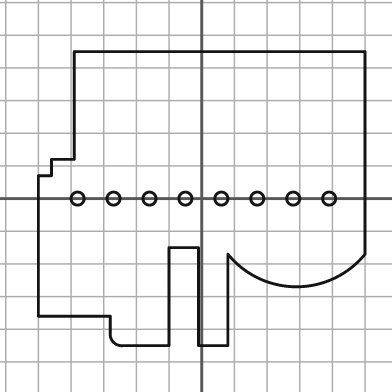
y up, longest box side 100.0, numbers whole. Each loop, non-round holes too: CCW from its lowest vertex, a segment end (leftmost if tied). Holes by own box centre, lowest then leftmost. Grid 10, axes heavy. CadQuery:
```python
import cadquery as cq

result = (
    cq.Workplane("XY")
    .moveTo(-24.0, -45.0)
    .lineTo(-10.0, -45.0)
    .lineTo(-10.0, -15.0)
    .lineTo(-1.0, -15.0)
    .lineTo(-1.0, -45.0)
    .lineTo(8.0, -45.0)
    .lineTo(8.0, -17.0)
    .threePointArc((29.0, -27.0), (50.0, -17.0))
    .lineTo(50.0, 45.0)
    .lineTo(-39.0, 45.0)
    .lineTo(-39.0, 12.0)
    .lineTo(-46.0, 12.0)
    .lineTo(-46.0, 7.0)
    .lineTo(-50.0, 7.0)
    .lineTo(-50.0, -36.0)
    .lineTo(-28.0, -36.0)
    .lineTo(-28.0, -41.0)
    .threePointArc((-27.0, -44.0), (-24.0, -45.0))
    .close()
    .moveTo(-38.0, 0.0)
    .circle(2.0)
    .moveTo(-27.0, 0.0)
    .circle(2.0)
    .moveTo(-16.0, 0.0)
    .circle(2.0)
    .moveTo(-5.0, 0.0)
    .circle(2.0)
    .moveTo(6.0, 0.0)
    .circle(2.0)
    .moveTo(17.0, 0.0)
    .circle(2.0)
    .moveTo(28.0, 0.0)
    .circle(2.0)
    .moveTo(39.0, 0.0)
    .circle(2.0)
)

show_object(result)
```